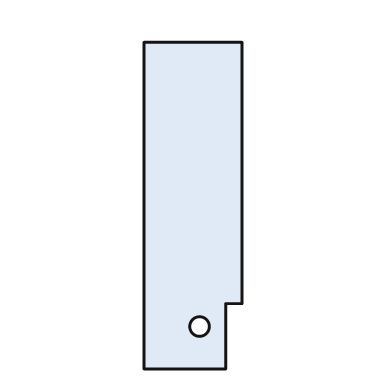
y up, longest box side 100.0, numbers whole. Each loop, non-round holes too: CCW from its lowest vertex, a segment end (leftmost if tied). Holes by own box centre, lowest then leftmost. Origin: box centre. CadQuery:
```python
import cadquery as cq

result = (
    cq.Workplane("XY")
    .moveTo(-15.0, -50.0)
    .lineTo(10.0, -50.0)
    .lineTo(10.0, -30.0)
    .lineTo(15.0, -30.0)
    .lineTo(15.0, 50.0)
    .lineTo(-15.0, 50.0)
    .close()
    .moveTo(2.0, -37.0)
    .circle(3.0)
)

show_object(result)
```